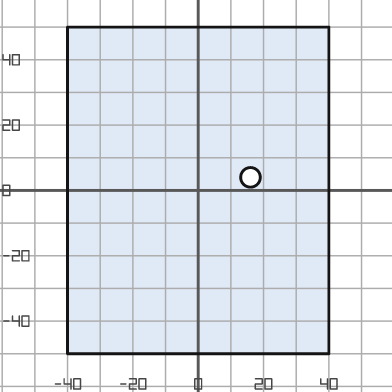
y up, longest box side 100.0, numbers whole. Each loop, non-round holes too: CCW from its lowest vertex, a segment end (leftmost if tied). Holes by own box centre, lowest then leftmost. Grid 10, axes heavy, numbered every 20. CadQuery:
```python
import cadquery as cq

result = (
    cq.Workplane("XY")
    .moveTo(-40.0, -50.0)
    .lineTo(40.0, -50.0)
    .lineTo(40.0, 50.0)
    .lineTo(-40.0, 50.0)
    .close()
    .moveTo(16.0, 4.0)
    .circle(3.0)
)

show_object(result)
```